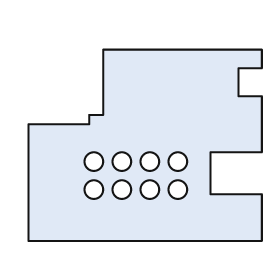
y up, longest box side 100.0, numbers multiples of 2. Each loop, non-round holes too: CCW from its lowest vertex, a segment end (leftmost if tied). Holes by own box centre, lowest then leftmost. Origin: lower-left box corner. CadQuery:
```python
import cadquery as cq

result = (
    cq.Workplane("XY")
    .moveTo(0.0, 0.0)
    .lineTo(100.0, 0.0)
    .lineTo(100.0, 20.0)
    .lineTo(78.0, 20.0)
    .lineTo(78.0, 38.0)
    .lineTo(100.0, 38.0)
    .lineTo(100.0, 62.0)
    .lineTo(90.0, 62.0)
    .lineTo(90.0, 74.0)
    .lineTo(100.0, 74.0)
    .lineTo(100.0, 82.0)
    .lineTo(32.0, 82.0)
    .lineTo(32.0, 54.0)
    .lineTo(26.0, 54.0)
    .lineTo(26.0, 50.0)
    .lineTo(0.0, 50.0)
    .close()
    .moveTo(28.0, 22.0)
    .circle(4.0)
    .moveTo(40.0, 22.0)
    .circle(4.0)
    .moveTo(52.0, 22.0)
    .circle(4.0)
    .moveTo(64.0, 22.0)
    .circle(4.0)
    .moveTo(28.0, 34.0)
    .circle(4.0)
    .moveTo(40.0, 34.0)
    .circle(4.0)
    .moveTo(52.0, 34.0)
    .circle(4.0)
    .moveTo(64.0, 34.0)
    .circle(4.0)
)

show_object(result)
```